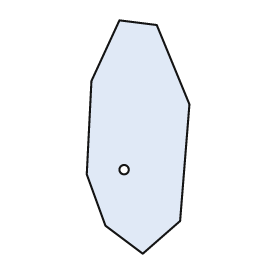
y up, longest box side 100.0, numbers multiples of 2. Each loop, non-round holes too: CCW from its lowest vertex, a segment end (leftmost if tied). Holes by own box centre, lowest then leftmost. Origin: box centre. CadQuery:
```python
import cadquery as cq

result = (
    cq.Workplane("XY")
    .moveTo(2.0, -50.0)
    .lineTo(18.0, -36.0)
    .lineTo(22.0, 14.0)
    .lineTo(8.0, 48.0)
    .lineTo(-8.0, 50.0)
    .lineTo(-20.0, 24.0)
    .lineTo(-22.0, -16.0)
    .lineTo(-14.0, -38.0)
    .close()
    .moveTo(-6.0, -14.0)
    .circle(2.0)
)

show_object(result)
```